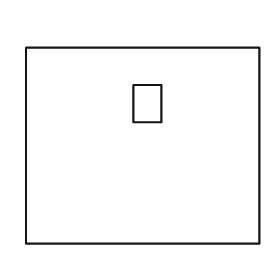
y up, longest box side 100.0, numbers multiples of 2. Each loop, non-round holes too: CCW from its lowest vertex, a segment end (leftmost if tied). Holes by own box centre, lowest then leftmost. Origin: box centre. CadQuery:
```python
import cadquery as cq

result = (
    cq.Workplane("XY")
    .moveTo(-50.0, -42.0)
    .lineTo(50.0, -42.0)
    .lineTo(50.0, 42.0)
    .lineTo(-50.0, 42.0)
    .close()
    .moveTo(-4.0, 10.0)
    .lineTo(8.0, 10.0)
    .lineTo(8.0, 26.0)
    .lineTo(-4.0, 26.0)
    .close()
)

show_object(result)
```